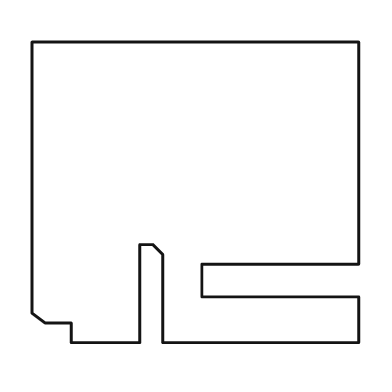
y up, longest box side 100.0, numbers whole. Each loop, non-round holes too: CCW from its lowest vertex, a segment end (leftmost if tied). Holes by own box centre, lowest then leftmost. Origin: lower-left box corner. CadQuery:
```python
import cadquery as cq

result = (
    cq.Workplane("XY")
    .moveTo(12.0, 0.0)
    .lineTo(33.0, 0.0)
    .lineTo(33.0, 30.0)
    .lineTo(37.0, 30.0)
    .lineTo(40.0, 27.0)
    .lineTo(40.0, 0.0)
    .lineTo(100.0, 0.0)
    .lineTo(100.0, 14.0)
    .lineTo(52.0, 14.0)
    .lineTo(52.0, 24.0)
    .lineTo(100.0, 24.0)
    .lineTo(100.0, 92.0)
    .lineTo(0.0, 92.0)
    .lineTo(0.0, 9.0)
    .lineTo(4.0, 6.0)
    .lineTo(12.0, 6.0)
    .close()
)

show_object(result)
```